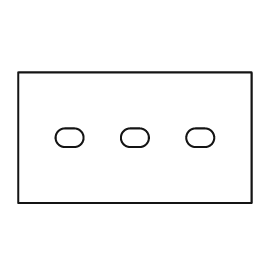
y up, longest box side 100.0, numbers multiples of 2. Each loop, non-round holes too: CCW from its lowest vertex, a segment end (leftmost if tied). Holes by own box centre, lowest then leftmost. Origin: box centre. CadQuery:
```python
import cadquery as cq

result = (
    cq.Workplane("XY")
    .moveTo(-50.0, -28.0)
    .lineTo(50.0, -28.0)
    .lineTo(50.0, 28.0)
    .lineTo(-50.0, 28.0)
    .close()
    .moveTo(-30.0, -4.0)
    .lineTo(-26.0, -4.0)
    .threePointArc((-22.0, 0.0), (-26.0, 4.0))
    .lineTo(-30.0, 4.0)
    .threePointArc((-34.0, 0.0), (-30.0, -4.0))
    .close()
    .moveTo(-2.0, -4.0)
    .lineTo(2.0, -4.0)
    .threePointArc((6.0, 0.0), (2.0, 4.0))
    .lineTo(-2.0, 4.0)
    .threePointArc((-6.0, 0.0), (-2.0, -4.0))
    .close()
    .moveTo(26.0, -4.0)
    .lineTo(30.0, -4.0)
    .threePointArc((34.0, 0.0), (30.0, 4.0))
    .lineTo(26.0, 4.0)
    .threePointArc((22.0, 0.0), (26.0, -4.0))
    .close()
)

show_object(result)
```